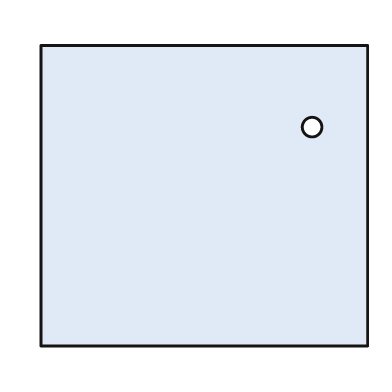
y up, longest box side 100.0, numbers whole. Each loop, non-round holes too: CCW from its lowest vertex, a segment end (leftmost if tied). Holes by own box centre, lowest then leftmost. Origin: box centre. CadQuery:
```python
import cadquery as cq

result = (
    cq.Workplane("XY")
    .moveTo(-50.0, -46.0)
    .lineTo(50.0, -46.0)
    .lineTo(50.0, 46.0)
    .lineTo(-50.0, 46.0)
    .close()
    .moveTo(33.0, 21.0)
    .circle(3.0)
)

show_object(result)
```